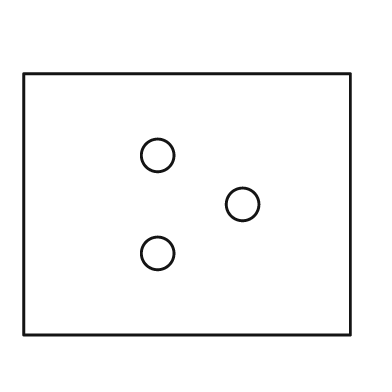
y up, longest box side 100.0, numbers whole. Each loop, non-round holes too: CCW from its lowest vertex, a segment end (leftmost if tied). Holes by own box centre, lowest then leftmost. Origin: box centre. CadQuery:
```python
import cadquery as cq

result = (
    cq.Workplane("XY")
    .moveTo(-50.0, -40.0)
    .lineTo(50.0, -40.0)
    .lineTo(50.0, 40.0)
    .lineTo(-50.0, 40.0)
    .close()
    .moveTo(-9.0, -15.0)
    .circle(5.0)
    .moveTo(17.0, 0.0)
    .circle(5.0)
    .moveTo(-9.0, 15.0)
    .circle(5.0)
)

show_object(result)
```